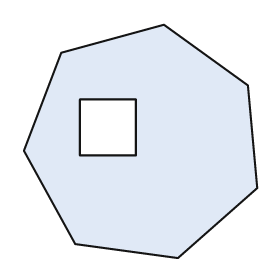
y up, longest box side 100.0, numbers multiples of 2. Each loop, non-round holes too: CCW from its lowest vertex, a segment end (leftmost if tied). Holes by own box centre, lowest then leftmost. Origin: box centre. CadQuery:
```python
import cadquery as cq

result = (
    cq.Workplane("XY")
    .moveTo(16.0, -50.0)
    .lineTo(50.0, -20.0)
    .lineTo(46.0, 24.0)
    .lineTo(10.0, 50.0)
    .lineTo(-34.0, 38.0)
    .lineTo(-50.0, -4.0)
    .lineTo(-28.0, -44.0)
    .close()
    .moveTo(-26.0, -6.0)
    .lineTo(-2.0, -6.0)
    .lineTo(-2.0, 18.0)
    .lineTo(-26.0, 18.0)
    .close()
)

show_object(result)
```